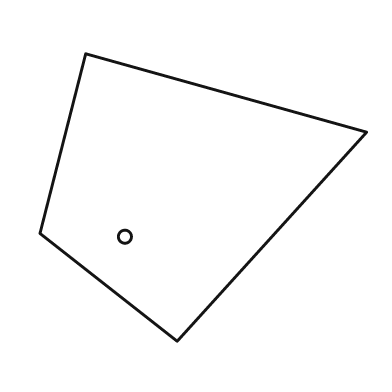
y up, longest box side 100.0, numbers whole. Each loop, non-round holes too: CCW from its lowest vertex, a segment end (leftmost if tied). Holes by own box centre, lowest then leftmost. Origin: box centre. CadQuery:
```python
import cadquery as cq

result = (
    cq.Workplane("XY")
    .moveTo(-8.0, -44.0)
    .lineTo(50.0, 20.0)
    .lineTo(-36.0, 44.0)
    .lineTo(-50.0, -11.0)
    .close()
    .moveTo(-24.0, -12.0)
    .circle(2.0)
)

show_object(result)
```